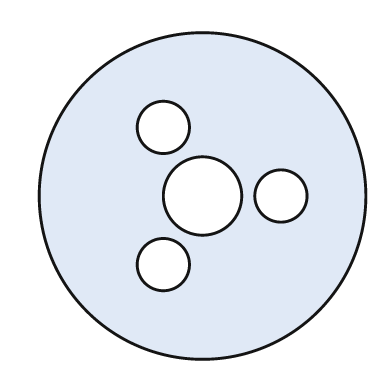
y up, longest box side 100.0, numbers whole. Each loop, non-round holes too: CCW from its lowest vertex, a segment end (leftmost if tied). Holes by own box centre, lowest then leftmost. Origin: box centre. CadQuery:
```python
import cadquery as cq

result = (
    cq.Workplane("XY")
    .moveTo(0.0, 0.0)
    .circle(50.0)
    .moveTo(-12.0, -21.0)
    .circle(8.0)
    .moveTo(0.0, 0.0)
    .circle(12.0)
    .moveTo(24.0, 0.0)
    .circle(8.0)
    .moveTo(-12.0, 21.0)
    .circle(8.0)
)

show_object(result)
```